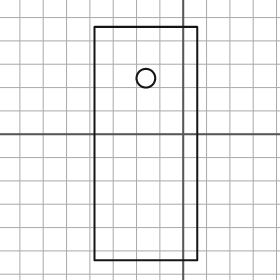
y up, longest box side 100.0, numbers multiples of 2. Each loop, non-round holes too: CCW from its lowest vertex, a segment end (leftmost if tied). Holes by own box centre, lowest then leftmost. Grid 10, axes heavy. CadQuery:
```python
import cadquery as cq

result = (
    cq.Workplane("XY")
    .moveTo(-38.0, -54.0)
    .lineTo(6.0, -54.0)
    .lineTo(6.0, 46.0)
    .lineTo(-38.0, 46.0)
    .close()
    .moveTo(-16.0, 24.0)
    .circle(4.0)
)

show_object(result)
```